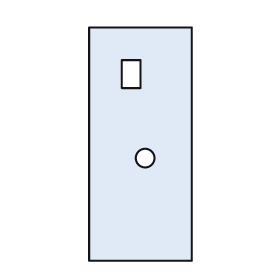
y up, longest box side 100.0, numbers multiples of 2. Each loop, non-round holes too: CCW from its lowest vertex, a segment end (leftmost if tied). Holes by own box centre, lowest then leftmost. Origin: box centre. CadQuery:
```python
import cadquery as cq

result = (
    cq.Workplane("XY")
    .moveTo(-22.0, -50.0)
    .lineTo(22.0, -50.0)
    .lineTo(22.0, 50.0)
    .lineTo(-22.0, 50.0)
    .close()
    .moveTo(2.0, -6.0)
    .circle(4.0)
    .moveTo(-8.0, 24.0)
    .lineTo(0.0, 24.0)
    .lineTo(0.0, 36.0)
    .lineTo(-8.0, 36.0)
    .close()
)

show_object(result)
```